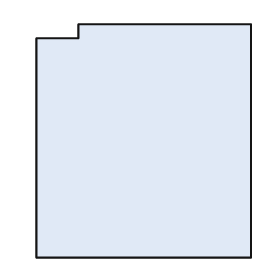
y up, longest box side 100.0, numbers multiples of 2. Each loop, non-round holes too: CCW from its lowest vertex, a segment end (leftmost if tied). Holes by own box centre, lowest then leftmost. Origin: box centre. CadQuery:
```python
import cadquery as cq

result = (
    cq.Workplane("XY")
    .moveTo(-46.0, -50.0)
    .lineTo(46.0, -50.0)
    .lineTo(46.0, 50.0)
    .lineTo(-28.0, 50.0)
    .lineTo(-28.0, 44.0)
    .lineTo(-46.0, 44.0)
    .close()
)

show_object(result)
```